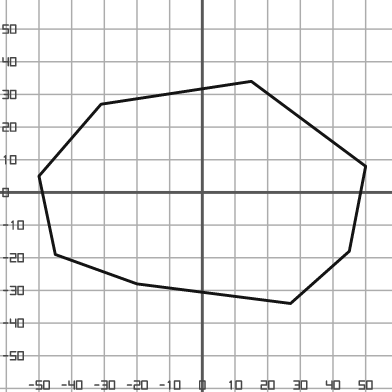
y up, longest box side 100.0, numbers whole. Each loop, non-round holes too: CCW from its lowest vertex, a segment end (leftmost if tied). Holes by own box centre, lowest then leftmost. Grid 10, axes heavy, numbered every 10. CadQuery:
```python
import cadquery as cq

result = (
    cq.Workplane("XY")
    .moveTo(27.0, -34.0)
    .lineTo(45.0, -18.0)
    .lineTo(50.0, 8.0)
    .lineTo(15.0, 34.0)
    .lineTo(-31.0, 27.0)
    .lineTo(-50.0, 5.0)
    .lineTo(-45.0, -19.0)
    .lineTo(-20.0, -28.0)
    .close()
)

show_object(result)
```